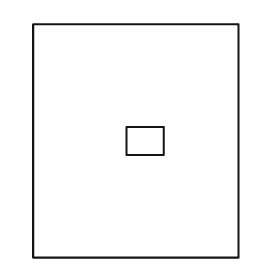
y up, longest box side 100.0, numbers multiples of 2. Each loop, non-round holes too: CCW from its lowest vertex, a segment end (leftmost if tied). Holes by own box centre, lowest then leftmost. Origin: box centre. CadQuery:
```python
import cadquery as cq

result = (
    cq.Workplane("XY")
    .moveTo(-44.0, -50.0)
    .lineTo(44.0, -50.0)
    .lineTo(44.0, 50.0)
    .lineTo(-44.0, 50.0)
    .close()
    .moveTo(-4.0, -6.0)
    .lineTo(12.0, -6.0)
    .lineTo(12.0, 6.0)
    .lineTo(-4.0, 6.0)
    .close()
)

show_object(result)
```